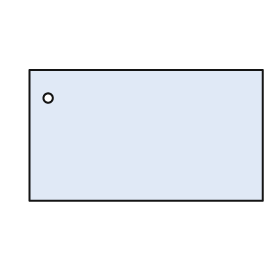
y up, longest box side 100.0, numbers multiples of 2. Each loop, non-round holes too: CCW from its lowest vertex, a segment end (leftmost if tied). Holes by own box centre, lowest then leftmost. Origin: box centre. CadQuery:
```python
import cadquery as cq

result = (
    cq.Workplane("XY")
    .moveTo(-50.0, -28.0)
    .lineTo(50.0, -28.0)
    .lineTo(50.0, 28.0)
    .lineTo(-50.0, 28.0)
    .close()
    .moveTo(-42.0, 16.0)
    .circle(2.0)
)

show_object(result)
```